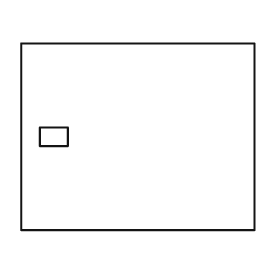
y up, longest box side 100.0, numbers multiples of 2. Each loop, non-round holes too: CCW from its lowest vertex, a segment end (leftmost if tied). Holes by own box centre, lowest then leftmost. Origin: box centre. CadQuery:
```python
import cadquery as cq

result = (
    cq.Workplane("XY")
    .moveTo(-50.0, -40.0)
    .lineTo(50.0, -40.0)
    .lineTo(50.0, 40.0)
    .lineTo(-50.0, 40.0)
    .close()
    .moveTo(-42.0, -4.0)
    .lineTo(-30.0, -4.0)
    .lineTo(-30.0, 4.0)
    .lineTo(-42.0, 4.0)
    .close()
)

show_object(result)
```